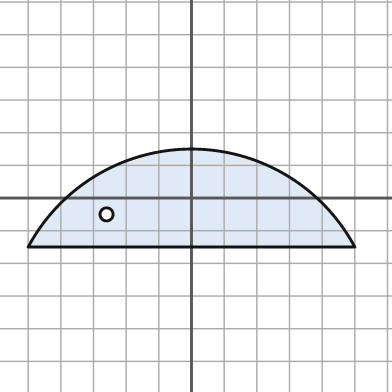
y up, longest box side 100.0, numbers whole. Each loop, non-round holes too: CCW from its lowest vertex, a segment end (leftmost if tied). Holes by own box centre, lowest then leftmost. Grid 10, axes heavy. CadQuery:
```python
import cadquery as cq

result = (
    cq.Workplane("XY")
    .moveTo(-50.0, -15.0)
    .lineTo(50.0, -15.0)
    .threePointArc((0.0, 15.0), (-50.0, -15.0))
    .close()
    .moveTo(-26.0, -5.0)
    .circle(2.0)
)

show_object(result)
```